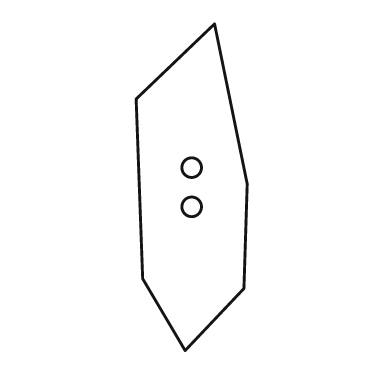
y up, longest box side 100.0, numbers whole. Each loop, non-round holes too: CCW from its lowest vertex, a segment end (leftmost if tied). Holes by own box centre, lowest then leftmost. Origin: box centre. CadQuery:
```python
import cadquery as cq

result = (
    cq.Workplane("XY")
    .moveTo(-2.0, -50.0)
    .lineTo(16.0, -31.0)
    .lineTo(17.0, 1.0)
    .lineTo(7.0, 50.0)
    .lineTo(-17.0, 27.0)
    .lineTo(-15.0, -28.0)
    .close()
    .moveTo(0.0, -6.0)
    .circle(3.0)
    .moveTo(0.0, 6.0)
    .circle(3.0)
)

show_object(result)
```